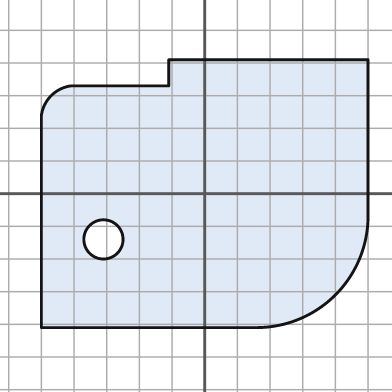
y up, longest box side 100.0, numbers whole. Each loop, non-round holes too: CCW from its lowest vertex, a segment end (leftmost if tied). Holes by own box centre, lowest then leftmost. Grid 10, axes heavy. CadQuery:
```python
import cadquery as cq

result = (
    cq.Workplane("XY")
    .moveTo(-50.0, -41.0)
    .lineTo(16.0, -41.0)
    .threePointArc((40.0, -31.0), (50.0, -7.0))
    .lineTo(50.0, 41.0)
    .lineTo(-11.0, 41.0)
    .lineTo(-11.0, 33.0)
    .lineTo(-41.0, 33.0)
    .threePointArc((-47.0, 30.0), (-50.0, 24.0))
    .close()
    .moveTo(-31.0, -14.0)
    .circle(6.0)
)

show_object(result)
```